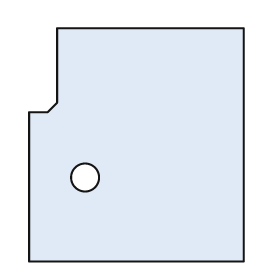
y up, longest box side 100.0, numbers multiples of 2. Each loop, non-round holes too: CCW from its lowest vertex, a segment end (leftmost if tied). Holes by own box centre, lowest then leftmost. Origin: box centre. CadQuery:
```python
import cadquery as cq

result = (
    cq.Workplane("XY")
    .moveTo(-46.0, -50.0)
    .lineTo(46.0, -50.0)
    .lineTo(46.0, 50.0)
    .lineTo(-34.0, 50.0)
    .lineTo(-34.0, 18.0)
    .lineTo(-38.0, 14.0)
    .lineTo(-46.0, 14.0)
    .close()
    .moveTo(-22.0, -14.0)
    .circle(6.0)
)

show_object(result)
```